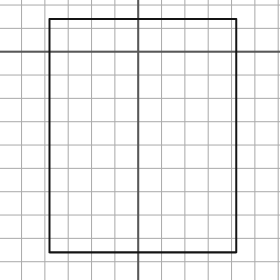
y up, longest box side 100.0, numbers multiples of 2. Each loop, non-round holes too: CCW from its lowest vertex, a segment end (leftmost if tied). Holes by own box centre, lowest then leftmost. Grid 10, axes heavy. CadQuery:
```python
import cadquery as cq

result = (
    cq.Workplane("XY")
    .moveTo(-38.0, -86.0)
    .lineTo(42.0, -86.0)
    .lineTo(42.0, 14.0)
    .lineTo(-38.0, 14.0)
    .close()
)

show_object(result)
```